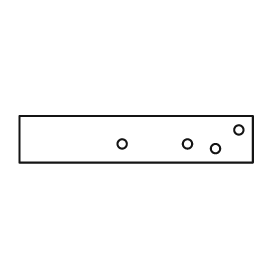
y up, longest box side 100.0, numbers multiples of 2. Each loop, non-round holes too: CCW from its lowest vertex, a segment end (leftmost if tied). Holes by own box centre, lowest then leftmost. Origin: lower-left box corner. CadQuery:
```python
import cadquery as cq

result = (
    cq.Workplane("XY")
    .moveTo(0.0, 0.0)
    .lineTo(100.0, 0.0)
    .lineTo(100.0, 20.0)
    .lineTo(0.0, 20.0)
    .close()
    .moveTo(84.0, 6.0)
    .circle(2.0)
    .moveTo(44.0, 8.0)
    .circle(2.0)
    .moveTo(72.0, 8.0)
    .circle(2.0)
    .moveTo(94.0, 14.0)
    .circle(2.0)
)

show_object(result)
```